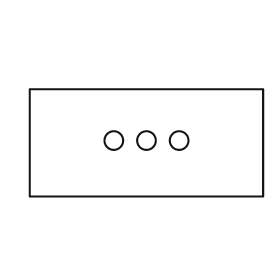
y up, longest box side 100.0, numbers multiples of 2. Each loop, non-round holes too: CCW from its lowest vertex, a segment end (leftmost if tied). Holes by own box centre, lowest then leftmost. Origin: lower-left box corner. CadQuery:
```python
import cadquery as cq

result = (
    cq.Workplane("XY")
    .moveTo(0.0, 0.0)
    .lineTo(100.0, 0.0)
    .lineTo(100.0, 46.0)
    .lineTo(0.0, 46.0)
    .close()
    .moveTo(36.0, 24.0)
    .circle(4.0)
    .moveTo(50.0, 24.0)
    .circle(4.0)
    .moveTo(64.0, 24.0)
    .circle(4.0)
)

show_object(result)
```